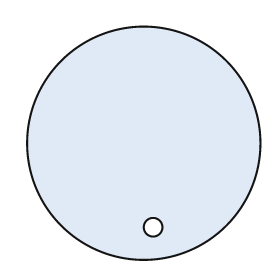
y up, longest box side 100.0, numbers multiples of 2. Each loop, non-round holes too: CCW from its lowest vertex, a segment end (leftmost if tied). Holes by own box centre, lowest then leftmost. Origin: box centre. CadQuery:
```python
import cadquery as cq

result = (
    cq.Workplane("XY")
    .moveTo(0.0, 0.0)
    .circle(50.0)
    .moveTo(4.0, -36.0)
    .circle(4.0)
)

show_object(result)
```